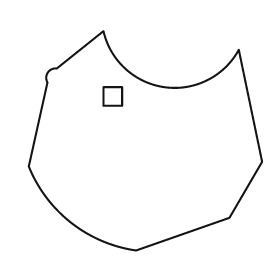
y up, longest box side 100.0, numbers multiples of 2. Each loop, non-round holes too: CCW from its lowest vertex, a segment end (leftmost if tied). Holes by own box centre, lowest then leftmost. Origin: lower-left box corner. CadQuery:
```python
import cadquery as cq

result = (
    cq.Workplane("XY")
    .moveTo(46.0, 0.0)
    .lineTo(86.0, 14.0)
    .lineTo(100.0, 38.0)
    .lineTo(90.0, 86.0)
    .threePointArc((58.0, 70.0), (32.0, 94.0))
    .lineTo(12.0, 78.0)
    .threePointArc((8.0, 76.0), (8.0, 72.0))
    .lineTo(0.0, 36.0)
    .threePointArc((18.0, 12.0), (46.0, 0.0))
    .close()
    .moveTo(32.0, 62.0)
    .lineTo(40.0, 62.0)
    .lineTo(40.0, 70.0)
    .lineTo(32.0, 70.0)
    .close()
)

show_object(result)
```